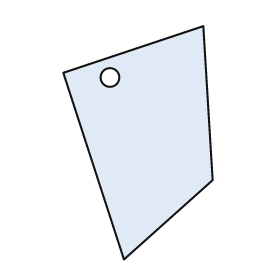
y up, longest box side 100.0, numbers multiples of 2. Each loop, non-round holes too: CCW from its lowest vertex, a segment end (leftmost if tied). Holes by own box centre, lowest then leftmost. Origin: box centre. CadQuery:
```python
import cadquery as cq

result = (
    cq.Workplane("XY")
    .moveTo(-6.0, -50.0)
    .lineTo(32.0, -16.0)
    .lineTo(28.0, 50.0)
    .lineTo(-32.0, 30.0)
    .close()
    .moveTo(-12.0, 28.0)
    .circle(4.0)
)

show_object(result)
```